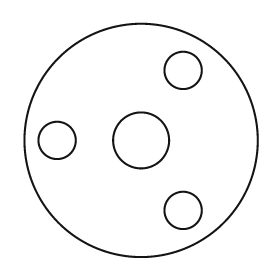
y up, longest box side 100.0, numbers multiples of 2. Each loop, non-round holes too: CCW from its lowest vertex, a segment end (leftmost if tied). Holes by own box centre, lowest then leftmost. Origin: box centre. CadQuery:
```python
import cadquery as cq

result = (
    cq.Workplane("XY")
    .moveTo(0.0, 0.0)
    .circle(50.0)
    .moveTo(18.0, -30.0)
    .circle(8.0)
    .moveTo(-36.0, 0.0)
    .circle(8.0)
    .moveTo(0.0, 0.0)
    .circle(12.0)
    .moveTo(18.0, 30.0)
    .circle(8.0)
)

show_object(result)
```